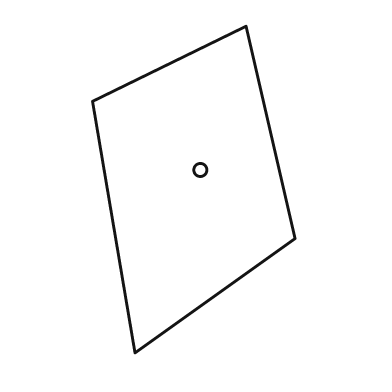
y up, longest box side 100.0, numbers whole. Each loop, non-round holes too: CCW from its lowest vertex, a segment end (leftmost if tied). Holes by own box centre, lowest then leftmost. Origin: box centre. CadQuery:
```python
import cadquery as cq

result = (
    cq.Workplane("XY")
    .moveTo(-18.0, -50.0)
    .lineTo(31.0, -15.0)
    .lineTo(16.0, 50.0)
    .lineTo(-31.0, 27.0)
    .close()
    .moveTo(2.0, 6.0)
    .circle(2.0)
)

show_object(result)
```